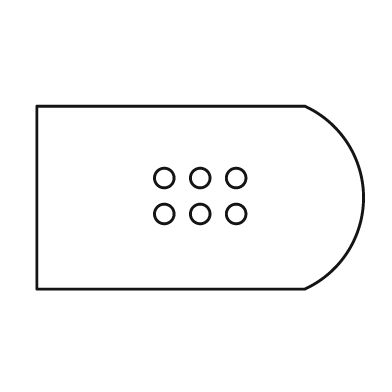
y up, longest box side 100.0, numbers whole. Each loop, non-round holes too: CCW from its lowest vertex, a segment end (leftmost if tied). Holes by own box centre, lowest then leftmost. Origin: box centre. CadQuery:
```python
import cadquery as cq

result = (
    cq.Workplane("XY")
    .moveTo(-50.0, -28.0)
    .lineTo(32.0, -28.0)
    .threePointArc((50.0, 0.0), (32.0, 28.0))
    .lineTo(-50.0, 28.0)
    .close()
    .moveTo(-11.0, -5.0)
    .circle(3.0)
    .moveTo(0.0, -5.0)
    .circle(3.0)
    .moveTo(11.0, -5.0)
    .circle(3.0)
    .moveTo(-11.0, 6.0)
    .circle(3.0)
    .moveTo(0.0, 6.0)
    .circle(3.0)
    .moveTo(11.0, 6.0)
    .circle(3.0)
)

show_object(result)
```